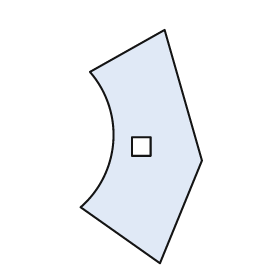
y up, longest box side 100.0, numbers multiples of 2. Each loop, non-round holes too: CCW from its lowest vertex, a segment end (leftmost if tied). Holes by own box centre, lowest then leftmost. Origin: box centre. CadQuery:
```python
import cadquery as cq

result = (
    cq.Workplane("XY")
    .moveTo(8.0, -50.0)
    .lineTo(26.0, -6.0)
    .lineTo(10.0, 50.0)
    .lineTo(-22.0, 32.0)
    .threePointArc((-12.0, 2.0), (-26.0, -26.0))
    .close()
    .moveTo(-4.0, -4.0)
    .lineTo(4.0, -4.0)
    .lineTo(4.0, 4.0)
    .lineTo(-4.0, 4.0)
    .close()
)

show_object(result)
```